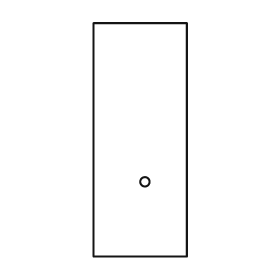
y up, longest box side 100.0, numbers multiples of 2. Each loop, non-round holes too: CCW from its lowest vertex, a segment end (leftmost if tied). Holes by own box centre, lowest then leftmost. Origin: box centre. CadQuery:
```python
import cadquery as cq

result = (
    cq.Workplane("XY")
    .moveTo(-20.0, -50.0)
    .lineTo(20.0, -50.0)
    .lineTo(20.0, 50.0)
    .lineTo(-20.0, 50.0)
    .close()
    .moveTo(2.0, -18.0)
    .circle(2.0)
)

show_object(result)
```